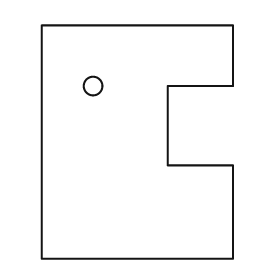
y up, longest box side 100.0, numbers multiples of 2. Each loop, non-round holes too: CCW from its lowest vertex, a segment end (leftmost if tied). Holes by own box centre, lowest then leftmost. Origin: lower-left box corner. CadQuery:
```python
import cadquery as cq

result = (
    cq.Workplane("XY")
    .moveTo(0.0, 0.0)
    .lineTo(82.0, 0.0)
    .lineTo(82.0, 40.0)
    .lineTo(54.0, 40.0)
    .lineTo(54.0, 74.0)
    .lineTo(82.0, 74.0)
    .lineTo(82.0, 100.0)
    .lineTo(0.0, 100.0)
    .close()
    .moveTo(22.0, 74.0)
    .circle(4.0)
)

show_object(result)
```